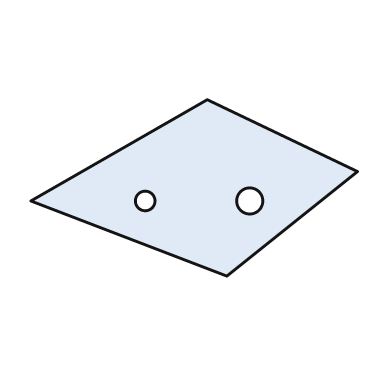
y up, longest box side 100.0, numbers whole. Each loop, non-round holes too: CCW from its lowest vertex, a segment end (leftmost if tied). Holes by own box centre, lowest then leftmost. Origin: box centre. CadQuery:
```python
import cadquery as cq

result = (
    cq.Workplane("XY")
    .moveTo(10.0, -27.0)
    .lineTo(50.0, 5.0)
    .lineTo(4.0, 27.0)
    .lineTo(-50.0, -4.0)
    .close()
    .moveTo(-15.0, -4.0)
    .circle(3.0)
    .moveTo(17.0, -4.0)
    .circle(4.0)
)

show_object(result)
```